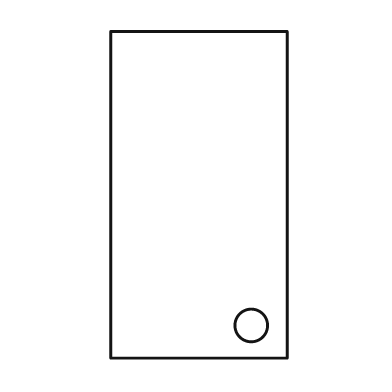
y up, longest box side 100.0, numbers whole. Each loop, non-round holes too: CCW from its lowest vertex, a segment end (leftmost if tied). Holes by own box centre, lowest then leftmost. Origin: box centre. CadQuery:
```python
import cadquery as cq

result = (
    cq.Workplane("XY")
    .moveTo(-27.0, -50.0)
    .lineTo(27.0, -50.0)
    .lineTo(27.0, 50.0)
    .lineTo(-27.0, 50.0)
    .close()
    .moveTo(16.0, -40.0)
    .circle(5.0)
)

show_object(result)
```